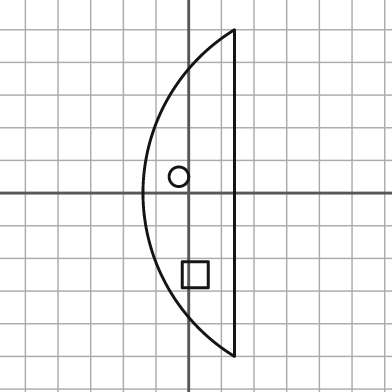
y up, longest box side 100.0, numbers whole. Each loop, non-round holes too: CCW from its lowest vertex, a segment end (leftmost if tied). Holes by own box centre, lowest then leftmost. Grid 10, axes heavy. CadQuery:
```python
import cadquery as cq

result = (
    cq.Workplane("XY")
    .moveTo(14.0, -50.0)
    .lineTo(14.0, 50.0)
    .threePointArc((-14.0, 0.0), (14.0, -50.0))
    .close()
    .moveTo(-2.0, -29.0)
    .lineTo(6.0, -29.0)
    .lineTo(6.0, -21.0)
    .lineTo(-2.0, -21.0)
    .close()
    .moveTo(-3.0, 5.0)
    .circle(3.0)
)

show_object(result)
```